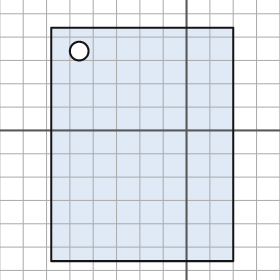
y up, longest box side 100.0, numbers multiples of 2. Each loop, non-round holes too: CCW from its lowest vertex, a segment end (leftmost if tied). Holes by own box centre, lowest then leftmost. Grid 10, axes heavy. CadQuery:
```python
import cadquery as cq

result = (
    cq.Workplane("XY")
    .moveTo(-58.0, -56.0)
    .lineTo(20.0, -56.0)
    .lineTo(20.0, 44.0)
    .lineTo(-58.0, 44.0)
    .close()
    .moveTo(-46.0, 34.0)
    .circle(4.0)
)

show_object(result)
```